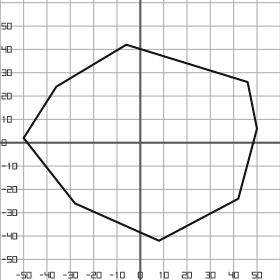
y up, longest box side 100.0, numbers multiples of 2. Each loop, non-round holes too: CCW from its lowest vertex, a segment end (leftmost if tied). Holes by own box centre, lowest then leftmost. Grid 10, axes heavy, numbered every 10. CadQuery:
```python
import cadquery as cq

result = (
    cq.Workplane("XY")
    .moveTo(8.0, -42.0)
    .lineTo(42.0, -24.0)
    .lineTo(50.0, 6.0)
    .lineTo(46.0, 26.0)
    .lineTo(-6.0, 42.0)
    .lineTo(-36.0, 24.0)
    .lineTo(-50.0, 2.0)
    .lineTo(-28.0, -26.0)
    .close()
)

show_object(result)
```